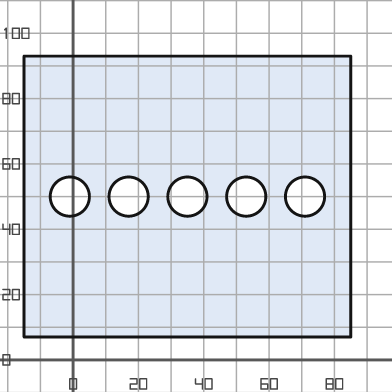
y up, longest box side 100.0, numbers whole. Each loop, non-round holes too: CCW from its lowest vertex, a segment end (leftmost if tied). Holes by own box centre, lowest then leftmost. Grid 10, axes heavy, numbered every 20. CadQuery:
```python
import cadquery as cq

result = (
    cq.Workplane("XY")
    .moveTo(-15.0, 7.0)
    .lineTo(85.0, 7.0)
    .lineTo(85.0, 93.0)
    .lineTo(-15.0, 93.0)
    .close()
    .moveTo(-1.0, 50.0)
    .circle(6.0)
    .moveTo(17.0, 50.0)
    .circle(6.0)
    .moveTo(35.0, 50.0)
    .circle(6.0)
    .moveTo(53.0, 50.0)
    .circle(6.0)
    .moveTo(71.0, 50.0)
    .circle(6.0)
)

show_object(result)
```